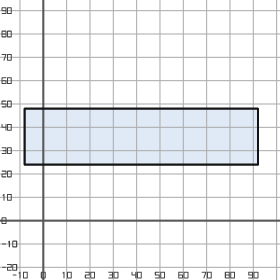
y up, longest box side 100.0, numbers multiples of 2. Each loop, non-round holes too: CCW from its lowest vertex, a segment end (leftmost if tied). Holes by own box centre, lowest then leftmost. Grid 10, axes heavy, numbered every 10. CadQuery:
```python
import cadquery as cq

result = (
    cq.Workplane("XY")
    .moveTo(-8.0, 24.0)
    .lineTo(92.0, 24.0)
    .lineTo(92.0, 48.0)
    .lineTo(-8.0, 48.0)
    .close()
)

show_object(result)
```